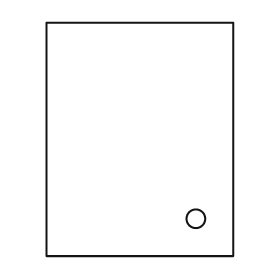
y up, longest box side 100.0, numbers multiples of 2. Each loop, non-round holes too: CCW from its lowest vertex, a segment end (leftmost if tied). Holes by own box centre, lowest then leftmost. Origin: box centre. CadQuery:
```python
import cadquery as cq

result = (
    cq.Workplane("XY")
    .moveTo(-40.0, -50.0)
    .lineTo(40.0, -50.0)
    .lineTo(40.0, 50.0)
    .lineTo(-40.0, 50.0)
    .close()
    .moveTo(24.0, -34.0)
    .circle(4.0)
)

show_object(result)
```